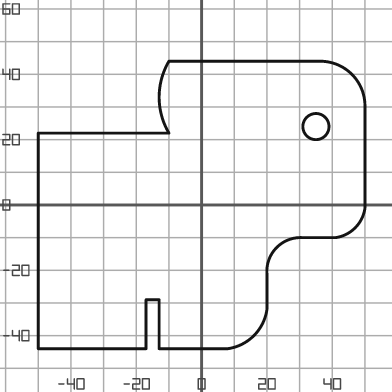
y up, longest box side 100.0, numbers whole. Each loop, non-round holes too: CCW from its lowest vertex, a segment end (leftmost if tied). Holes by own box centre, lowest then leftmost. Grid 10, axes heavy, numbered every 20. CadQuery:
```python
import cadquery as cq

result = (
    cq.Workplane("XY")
    .moveTo(-50.0, -44.0)
    .lineTo(-17.0, -44.0)
    .lineTo(-17.0, -29.0)
    .lineTo(-13.0, -29.0)
    .lineTo(-13.0, -44.0)
    .lineTo(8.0, -44.0)
    .threePointArc((16.0, -40.0), (20.0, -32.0))
    .lineTo(20.0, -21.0)
    .threePointArc((23.0, -13.0), (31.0, -10.0))
    .lineTo(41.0, -10.0)
    .threePointArc((47.0, -7.0), (50.0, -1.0))
    .lineTo(50.0, 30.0)
    .threePointArc((46.0, 40.0), (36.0, 44.0))
    .lineTo(-10.0, 44.0)
    .threePointArc((-13.0, 33.0), (-10.0, 22.0))
    .lineTo(-50.0, 22.0)
    .close()
    .moveTo(35.0, 24.0)
    .circle(4.0)
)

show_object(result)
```